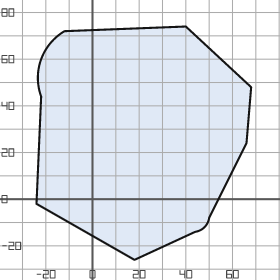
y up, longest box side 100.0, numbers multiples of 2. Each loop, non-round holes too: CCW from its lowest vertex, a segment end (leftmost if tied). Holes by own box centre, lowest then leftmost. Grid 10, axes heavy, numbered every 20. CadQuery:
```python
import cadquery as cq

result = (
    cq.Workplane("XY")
    .moveTo(18.0, -26.0)
    .lineTo(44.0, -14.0)
    .threePointArc((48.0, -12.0), (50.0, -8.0))
    .lineTo(66.0, 24.0)
    .lineTo(68.0, 48.0)
    .lineTo(40.0, 74.0)
    .lineTo(-12.0, 72.0)
    .threePointArc((-22.0, 60.0), (-22.0, 44.0))
    .lineTo(-24.0, -2.0)
    .close()
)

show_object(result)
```